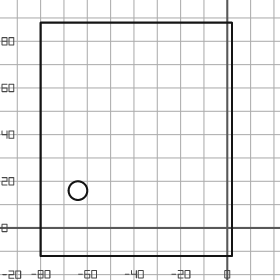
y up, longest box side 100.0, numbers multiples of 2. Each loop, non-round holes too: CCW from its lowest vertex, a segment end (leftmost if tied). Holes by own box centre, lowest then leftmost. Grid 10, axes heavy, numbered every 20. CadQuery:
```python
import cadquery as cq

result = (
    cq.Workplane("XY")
    .moveTo(-80.0, -12.0)
    .lineTo(2.0, -12.0)
    .lineTo(2.0, 88.0)
    .lineTo(-80.0, 88.0)
    .close()
    .moveTo(-64.0, 16.0)
    .circle(4.0)
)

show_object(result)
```